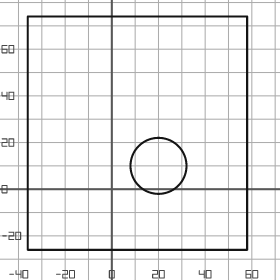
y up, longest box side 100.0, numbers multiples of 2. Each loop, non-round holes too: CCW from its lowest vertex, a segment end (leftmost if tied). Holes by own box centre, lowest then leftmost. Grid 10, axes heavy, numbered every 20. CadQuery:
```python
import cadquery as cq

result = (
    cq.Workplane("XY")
    .moveTo(-36.0, -26.0)
    .lineTo(58.0, -26.0)
    .lineTo(58.0, 74.0)
    .lineTo(-36.0, 74.0)
    .close()
    .moveTo(20.0, 10.0)
    .circle(12.0)
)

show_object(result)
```